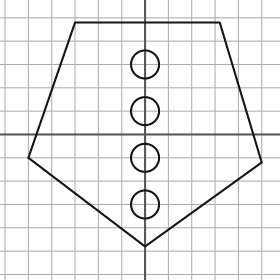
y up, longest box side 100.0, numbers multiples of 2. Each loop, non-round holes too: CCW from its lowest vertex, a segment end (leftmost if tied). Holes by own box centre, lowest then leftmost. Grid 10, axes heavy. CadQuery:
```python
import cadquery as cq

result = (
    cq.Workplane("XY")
    .moveTo(0.0, -48.0)
    .lineTo(50.0, -12.0)
    .lineTo(32.0, 48.0)
    .lineTo(-30.0, 48.0)
    .lineTo(-50.0, -10.0)
    .close()
    .moveTo(0.0, -30.0)
    .circle(6.0)
    .moveTo(0.0, -10.0)
    .circle(6.0)
    .moveTo(0.0, 10.0)
    .circle(6.0)
    .moveTo(0.0, 30.0)
    .circle(6.0)
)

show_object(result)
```